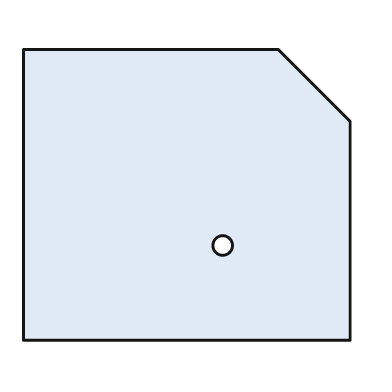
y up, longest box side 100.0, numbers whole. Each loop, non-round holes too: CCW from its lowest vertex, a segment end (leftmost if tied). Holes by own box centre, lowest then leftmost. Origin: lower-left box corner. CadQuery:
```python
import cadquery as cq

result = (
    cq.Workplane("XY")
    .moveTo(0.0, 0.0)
    .lineTo(100.0, 0.0)
    .lineTo(100.0, 67.0)
    .lineTo(78.0, 89.0)
    .lineTo(0.0, 89.0)
    .close()
    .moveTo(61.0, 29.0)
    .circle(3.0)
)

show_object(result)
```